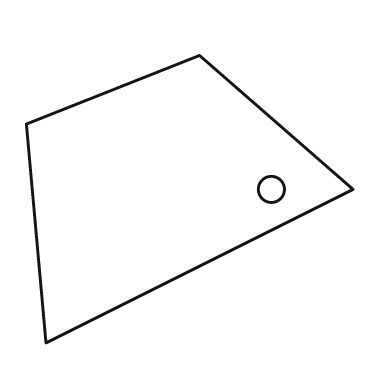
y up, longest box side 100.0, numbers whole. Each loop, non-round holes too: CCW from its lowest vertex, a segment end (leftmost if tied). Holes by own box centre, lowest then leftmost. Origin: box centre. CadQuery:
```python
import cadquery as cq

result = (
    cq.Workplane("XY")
    .moveTo(-44.0, -44.0)
    .lineTo(50.0, 3.0)
    .lineTo(3.0, 44.0)
    .lineTo(-50.0, 23.0)
    .close()
    .moveTo(25.0, 3.0)
    .circle(4.0)
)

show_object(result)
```